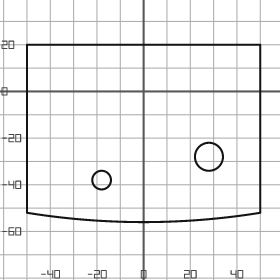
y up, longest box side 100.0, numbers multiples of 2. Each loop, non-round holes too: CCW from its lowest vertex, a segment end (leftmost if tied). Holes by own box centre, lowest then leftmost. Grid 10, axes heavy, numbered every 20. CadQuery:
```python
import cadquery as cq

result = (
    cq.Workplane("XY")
    .moveTo(-50.0, -52.0)
    .threePointArc((0.0, -56.0), (50.0, -52.0))
    .lineTo(50.0, 20.0)
    .lineTo(-50.0, 20.0)
    .close()
    .moveTo(-18.0, -38.0)
    .circle(4.0)
    .moveTo(28.0, -28.0)
    .circle(6.0)
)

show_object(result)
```